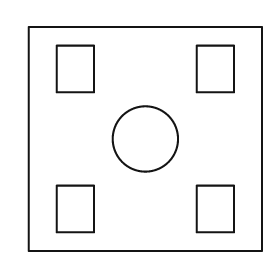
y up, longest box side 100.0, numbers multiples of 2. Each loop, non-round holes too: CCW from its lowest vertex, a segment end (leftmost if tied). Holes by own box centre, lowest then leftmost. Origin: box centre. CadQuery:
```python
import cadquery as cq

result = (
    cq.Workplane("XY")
    .moveTo(-50.0, -48.0)
    .lineTo(50.0, -48.0)
    .lineTo(50.0, 48.0)
    .lineTo(-50.0, 48.0)
    .close()
    .moveTo(-38.0, -40.0)
    .lineTo(-22.0, -40.0)
    .lineTo(-22.0, -20.0)
    .lineTo(-38.0, -20.0)
    .close()
    .moveTo(22.0, -40.0)
    .lineTo(38.0, -40.0)
    .lineTo(38.0, -20.0)
    .lineTo(22.0, -20.0)
    .close()
    .moveTo(0.0, 0.0)
    .circle(14.0)
    .moveTo(-38.0, 20.0)
    .lineTo(-22.0, 20.0)
    .lineTo(-22.0, 40.0)
    .lineTo(-38.0, 40.0)
    .close()
    .moveTo(22.0, 20.0)
    .lineTo(38.0, 20.0)
    .lineTo(38.0, 40.0)
    .lineTo(22.0, 40.0)
    .close()
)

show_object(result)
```